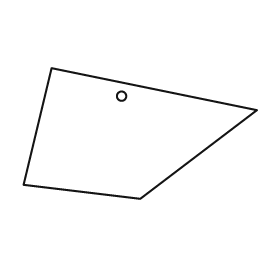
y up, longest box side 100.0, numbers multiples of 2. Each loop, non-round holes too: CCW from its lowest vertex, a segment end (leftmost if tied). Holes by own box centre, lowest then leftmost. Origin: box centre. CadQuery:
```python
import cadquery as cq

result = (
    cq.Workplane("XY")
    .moveTo(0.0, -28.0)
    .lineTo(50.0, 10.0)
    .lineTo(-38.0, 28.0)
    .lineTo(-50.0, -22.0)
    .close()
    .moveTo(-8.0, 16.0)
    .circle(2.0)
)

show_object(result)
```